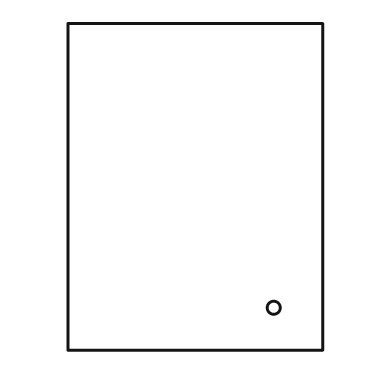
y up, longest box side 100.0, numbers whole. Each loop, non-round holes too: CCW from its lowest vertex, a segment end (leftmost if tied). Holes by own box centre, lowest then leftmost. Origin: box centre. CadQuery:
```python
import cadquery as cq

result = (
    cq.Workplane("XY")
    .moveTo(-39.0, -50.0)
    .lineTo(39.0, -50.0)
    .lineTo(39.0, 50.0)
    .lineTo(-39.0, 50.0)
    .close()
    .moveTo(24.0, -37.0)
    .circle(2.0)
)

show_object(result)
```